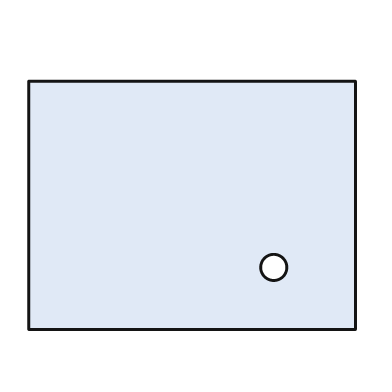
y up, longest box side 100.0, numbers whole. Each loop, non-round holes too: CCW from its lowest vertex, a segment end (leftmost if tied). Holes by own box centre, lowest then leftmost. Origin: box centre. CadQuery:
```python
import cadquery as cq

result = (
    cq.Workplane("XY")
    .moveTo(-50.0, -38.0)
    .lineTo(50.0, -38.0)
    .lineTo(50.0, 38.0)
    .lineTo(-50.0, 38.0)
    .close()
    .moveTo(25.0, -19.0)
    .circle(4.0)
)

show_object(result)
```